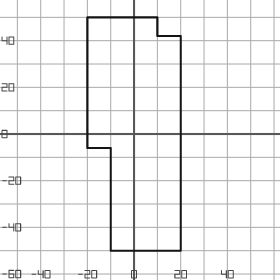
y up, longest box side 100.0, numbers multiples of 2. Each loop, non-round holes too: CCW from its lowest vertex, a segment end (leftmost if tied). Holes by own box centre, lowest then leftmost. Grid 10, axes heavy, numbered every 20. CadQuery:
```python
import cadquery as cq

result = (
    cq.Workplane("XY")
    .moveTo(-10.0, -50.0)
    .lineTo(20.0, -50.0)
    .lineTo(20.0, 42.0)
    .lineTo(10.0, 42.0)
    .lineTo(10.0, 50.0)
    .lineTo(-20.0, 50.0)
    .lineTo(-20.0, -6.0)
    .lineTo(-10.0, -6.0)
    .close()
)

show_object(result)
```